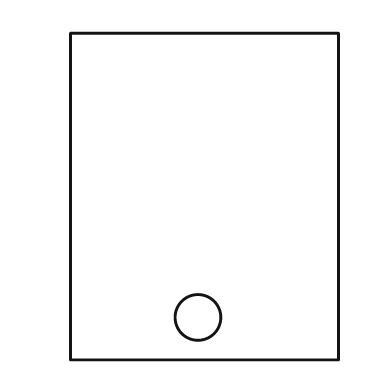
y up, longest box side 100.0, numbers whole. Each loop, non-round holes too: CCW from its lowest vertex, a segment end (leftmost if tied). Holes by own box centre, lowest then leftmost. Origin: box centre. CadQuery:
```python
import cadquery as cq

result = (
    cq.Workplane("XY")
    .moveTo(-41.0, -50.0)
    .lineTo(41.0, -50.0)
    .lineTo(41.0, 50.0)
    .lineTo(-41.0, 50.0)
    .close()
    .moveTo(-2.0, -37.0)
    .circle(7.0)
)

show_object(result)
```